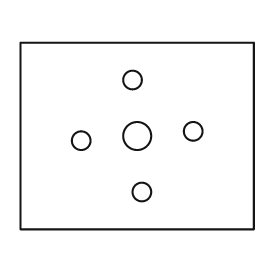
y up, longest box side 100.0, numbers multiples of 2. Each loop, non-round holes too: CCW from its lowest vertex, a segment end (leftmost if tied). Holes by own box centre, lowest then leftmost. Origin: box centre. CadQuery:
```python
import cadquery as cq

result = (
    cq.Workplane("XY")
    .moveTo(-50.0, -40.0)
    .lineTo(50.0, -40.0)
    .lineTo(50.0, 40.0)
    .lineTo(-50.0, 40.0)
    .close()
    .moveTo(2.0, -24.0)
    .circle(4.0)
    .moveTo(-24.0, -2.0)
    .circle(4.0)
    .moveTo(0.0, 0.0)
    .circle(6.0)
    .moveTo(24.0, 2.0)
    .circle(4.0)
    .moveTo(-2.0, 24.0)
    .circle(4.0)
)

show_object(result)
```